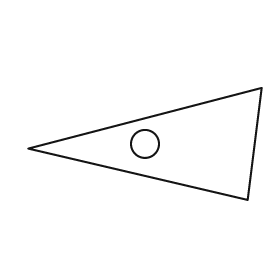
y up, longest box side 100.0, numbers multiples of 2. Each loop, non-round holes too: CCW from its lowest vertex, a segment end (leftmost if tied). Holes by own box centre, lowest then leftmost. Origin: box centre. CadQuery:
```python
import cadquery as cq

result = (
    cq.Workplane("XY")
    .moveTo(44.0, -24.0)
    .lineTo(50.0, 24.0)
    .lineTo(-50.0, -2.0)
    .close()
    .moveTo(0.0, 0.0)
    .circle(6.0)
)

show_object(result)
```